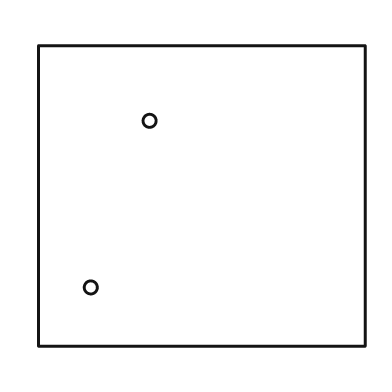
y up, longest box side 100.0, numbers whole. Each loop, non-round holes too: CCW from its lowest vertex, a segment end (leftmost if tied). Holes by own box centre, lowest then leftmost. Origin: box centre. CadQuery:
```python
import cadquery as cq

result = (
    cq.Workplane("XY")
    .moveTo(-50.0, -46.0)
    .lineTo(50.0, -46.0)
    .lineTo(50.0, 46.0)
    .lineTo(-50.0, 46.0)
    .close()
    .moveTo(-34.0, -28.0)
    .circle(2.0)
    .moveTo(-16.0, 23.0)
    .circle(2.0)
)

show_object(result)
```